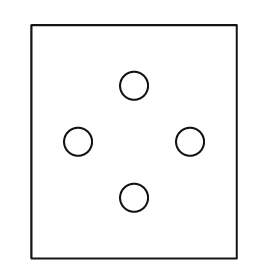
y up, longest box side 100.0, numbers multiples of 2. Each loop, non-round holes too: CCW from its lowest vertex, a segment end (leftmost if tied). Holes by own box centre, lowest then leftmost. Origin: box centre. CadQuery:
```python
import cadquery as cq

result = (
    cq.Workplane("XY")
    .moveTo(-44.0, -50.0)
    .lineTo(44.0, -50.0)
    .lineTo(44.0, 50.0)
    .lineTo(-44.0, 50.0)
    .close()
    .moveTo(0.0, -24.0)
    .circle(6.0)
    .moveTo(-24.0, 0.0)
    .circle(6.0)
    .moveTo(24.0, 0.0)
    .circle(6.0)
    .moveTo(0.0, 24.0)
    .circle(6.0)
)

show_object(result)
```